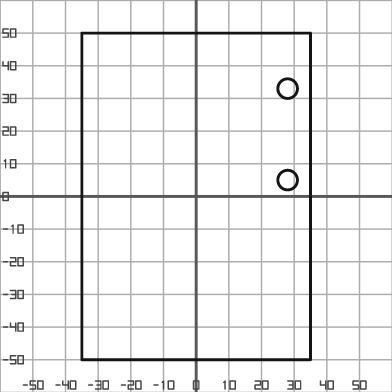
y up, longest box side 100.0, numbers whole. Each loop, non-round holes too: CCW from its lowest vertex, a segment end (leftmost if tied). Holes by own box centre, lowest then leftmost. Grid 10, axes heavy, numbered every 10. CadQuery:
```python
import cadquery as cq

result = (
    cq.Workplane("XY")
    .moveTo(-35.0, -50.0)
    .lineTo(35.0, -50.0)
    .lineTo(35.0, 50.0)
    .lineTo(-35.0, 50.0)
    .close()
    .moveTo(28.0, 5.0)
    .circle(3.0)
    .moveTo(28.0, 33.0)
    .circle(3.0)
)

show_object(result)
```